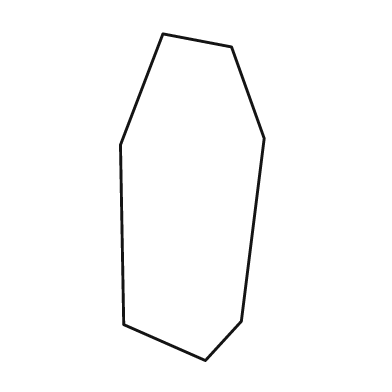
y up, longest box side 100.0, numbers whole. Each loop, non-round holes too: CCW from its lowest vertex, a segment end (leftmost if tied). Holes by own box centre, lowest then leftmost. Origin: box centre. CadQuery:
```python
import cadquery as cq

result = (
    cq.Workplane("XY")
    .moveTo(4.0, -50.0)
    .lineTo(15.0, -38.0)
    .lineTo(22.0, 18.0)
    .lineTo(12.0, 46.0)
    .lineTo(-9.0, 50.0)
    .lineTo(-22.0, 16.0)
    .lineTo(-21.0, -39.0)
    .close()
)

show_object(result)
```